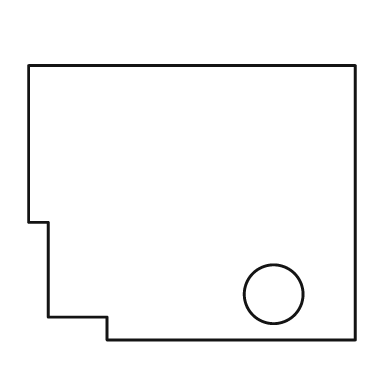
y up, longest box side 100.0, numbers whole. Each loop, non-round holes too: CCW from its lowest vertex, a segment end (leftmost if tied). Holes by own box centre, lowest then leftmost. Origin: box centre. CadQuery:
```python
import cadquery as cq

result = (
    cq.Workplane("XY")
    .moveTo(-26.0, -42.0)
    .lineTo(50.0, -42.0)
    .lineTo(50.0, 42.0)
    .lineTo(-50.0, 42.0)
    .lineTo(-50.0, -6.0)
    .lineTo(-44.0, -6.0)
    .lineTo(-44.0, -35.0)
    .lineTo(-26.0, -35.0)
    .close()
    .moveTo(25.0, -28.0)
    .circle(9.0)
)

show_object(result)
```